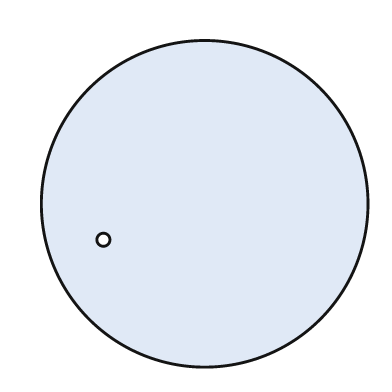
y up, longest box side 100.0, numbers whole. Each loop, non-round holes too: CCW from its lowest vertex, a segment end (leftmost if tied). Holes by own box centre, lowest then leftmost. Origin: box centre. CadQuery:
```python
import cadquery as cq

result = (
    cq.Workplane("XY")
    .moveTo(0.0, 0.0)
    .circle(50.0)
    .moveTo(-31.0, -11.0)
    .circle(2.0)
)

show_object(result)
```